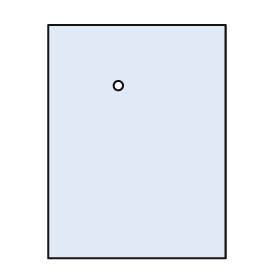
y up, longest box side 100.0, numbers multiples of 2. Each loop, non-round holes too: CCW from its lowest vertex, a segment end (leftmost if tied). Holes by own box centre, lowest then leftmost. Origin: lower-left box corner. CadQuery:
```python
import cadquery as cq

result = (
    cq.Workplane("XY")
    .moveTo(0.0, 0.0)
    .lineTo(76.0, 0.0)
    .lineTo(76.0, 100.0)
    .lineTo(0.0, 100.0)
    .close()
    .moveTo(30.0, 74.0)
    .circle(2.0)
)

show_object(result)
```